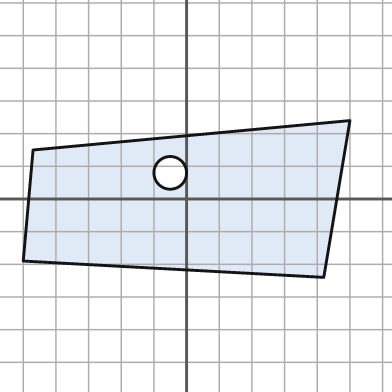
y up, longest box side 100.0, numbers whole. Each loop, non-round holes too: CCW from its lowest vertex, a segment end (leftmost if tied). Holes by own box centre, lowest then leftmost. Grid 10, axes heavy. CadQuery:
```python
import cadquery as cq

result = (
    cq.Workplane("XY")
    .moveTo(42.0, -24.0)
    .lineTo(50.0, 24.0)
    .lineTo(-47.0, 15.0)
    .lineTo(-50.0, -19.0)
    .close()
    .moveTo(-5.0, 8.0)
    .circle(5.0)
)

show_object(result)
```